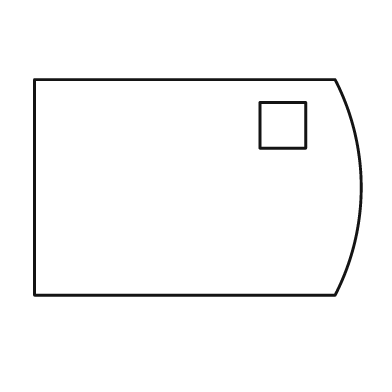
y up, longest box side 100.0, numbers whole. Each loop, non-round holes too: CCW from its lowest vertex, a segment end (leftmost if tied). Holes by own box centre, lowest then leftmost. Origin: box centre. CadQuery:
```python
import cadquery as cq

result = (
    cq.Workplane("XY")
    .moveTo(-50.0, -33.0)
    .lineTo(42.0, -33.0)
    .threePointArc((50.0, 0.0), (42.0, 33.0))
    .lineTo(-50.0, 33.0)
    .close()
    .moveTo(19.0, 12.0)
    .lineTo(33.0, 12.0)
    .lineTo(33.0, 26.0)
    .lineTo(19.0, 26.0)
    .close()
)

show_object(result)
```